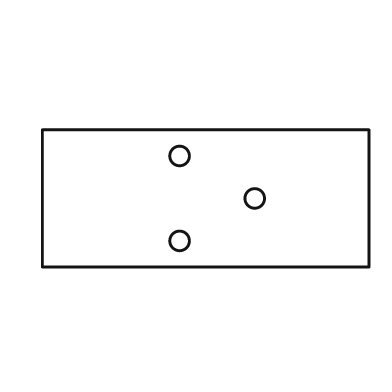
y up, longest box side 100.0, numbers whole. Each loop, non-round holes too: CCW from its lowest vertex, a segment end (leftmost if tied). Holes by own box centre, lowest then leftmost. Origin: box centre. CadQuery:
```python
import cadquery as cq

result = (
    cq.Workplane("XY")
    .moveTo(-50.0, -21.0)
    .lineTo(50.0, -21.0)
    .lineTo(50.0, 21.0)
    .lineTo(-50.0, 21.0)
    .close()
    .moveTo(-8.0, -13.0)
    .circle(3.0)
    .moveTo(15.0, 0.0)
    .circle(3.0)
    .moveTo(-8.0, 13.0)
    .circle(3.0)
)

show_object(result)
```